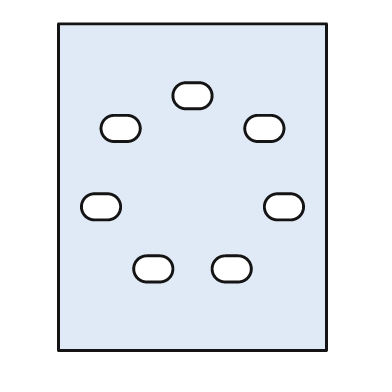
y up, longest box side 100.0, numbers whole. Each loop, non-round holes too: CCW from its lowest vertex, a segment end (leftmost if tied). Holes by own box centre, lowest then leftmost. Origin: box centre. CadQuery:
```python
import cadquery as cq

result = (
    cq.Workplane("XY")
    .moveTo(-41.0, -50.0)
    .lineTo(41.0, -50.0)
    .lineTo(41.0, 50.0)
    .lineTo(-41.0, 50.0)
    .close()
    .moveTo(-14.0, -29.0)
    .lineTo(-10.0, -29.0)
    .threePointArc((-6.0, -25.0), (-10.0, -21.0))
    .lineTo(-14.0, -21.0)
    .threePointArc((-18.0, -25.0), (-14.0, -29.0))
    .close()
    .moveTo(10.0, -29.0)
    .lineTo(14.0, -29.0)
    .threePointArc((18.0, -25.0), (14.0, -21.0))
    .lineTo(10.0, -21.0)
    .threePointArc((6.0, -25.0), (10.0, -29.0))
    .close()
    .moveTo(-30.0, -10.0)
    .lineTo(-26.0, -10.0)
    .threePointArc((-22.0, -6.0), (-26.0, -2.0))
    .lineTo(-30.0, -2.0)
    .threePointArc((-34.0, -6.0), (-30.0, -10.0))
    .close()
    .moveTo(26.0, -10.0)
    .lineTo(30.0, -10.0)
    .threePointArc((34.0, -6.0), (30.0, -2.0))
    .lineTo(26.0, -2.0)
    .threePointArc((22.0, -6.0), (26.0, -10.0))
    .close()
    .moveTo(-24.0, 14.0)
    .lineTo(-20.0, 14.0)
    .threePointArc((-16.0, 18.0), (-20.0, 22.0))
    .lineTo(-24.0, 22.0)
    .threePointArc((-28.0, 18.0), (-24.0, 14.0))
    .close()
    .moveTo(20.0, 14.0)
    .lineTo(24.0, 14.0)
    .threePointArc((28.0, 18.0), (24.0, 22.0))
    .lineTo(20.0, 22.0)
    .threePointArc((16.0, 18.0), (20.0, 14.0))
    .close()
    .moveTo(-2.0, 24.0)
    .lineTo(2.0, 24.0)
    .threePointArc((6.0, 28.0), (2.0, 32.0))
    .lineTo(-2.0, 32.0)
    .threePointArc((-6.0, 28.0), (-2.0, 24.0))
    .close()
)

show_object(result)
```